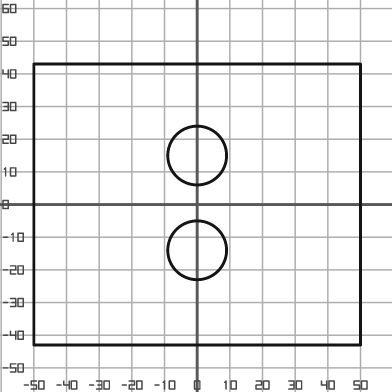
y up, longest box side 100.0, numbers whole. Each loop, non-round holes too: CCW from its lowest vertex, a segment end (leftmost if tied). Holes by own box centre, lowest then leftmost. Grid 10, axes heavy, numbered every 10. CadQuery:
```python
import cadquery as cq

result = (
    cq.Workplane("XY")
    .moveTo(-50.0, -43.0)
    .lineTo(50.0, -43.0)
    .lineTo(50.0, 43.0)
    .lineTo(-50.0, 43.0)
    .close()
    .moveTo(0.0, -14.0)
    .circle(9.0)
    .moveTo(0.0, 15.0)
    .circle(9.0)
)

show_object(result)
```